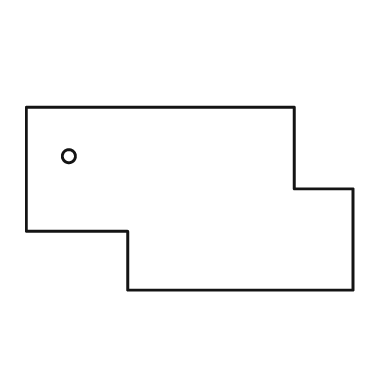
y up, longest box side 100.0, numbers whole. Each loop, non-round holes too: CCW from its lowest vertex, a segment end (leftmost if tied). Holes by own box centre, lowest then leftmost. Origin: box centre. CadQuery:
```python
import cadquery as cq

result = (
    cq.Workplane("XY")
    .moveTo(-19.0, -28.0)
    .lineTo(50.0, -28.0)
    .lineTo(50.0, 3.0)
    .lineTo(32.0, 3.0)
    .lineTo(32.0, 28.0)
    .lineTo(-50.0, 28.0)
    .lineTo(-50.0, -10.0)
    .lineTo(-19.0, -10.0)
    .close()
    .moveTo(-37.0, 13.0)
    .circle(2.0)
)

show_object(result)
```